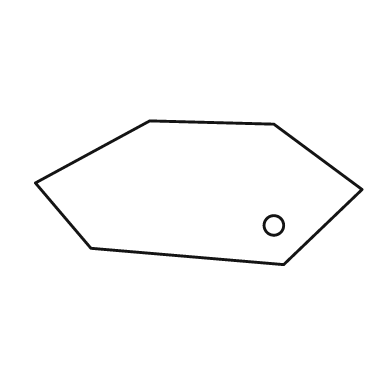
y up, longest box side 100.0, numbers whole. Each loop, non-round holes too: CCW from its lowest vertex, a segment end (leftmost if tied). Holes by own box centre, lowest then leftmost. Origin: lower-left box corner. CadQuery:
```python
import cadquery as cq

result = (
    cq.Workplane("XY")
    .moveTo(76.0, 0.0)
    .lineTo(100.0, 23.0)
    .lineTo(73.0, 43.0)
    .lineTo(35.0, 44.0)
    .lineTo(0.0, 25.0)
    .lineTo(17.0, 5.0)
    .close()
    .moveTo(73.0, 12.0)
    .circle(3.0)
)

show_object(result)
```